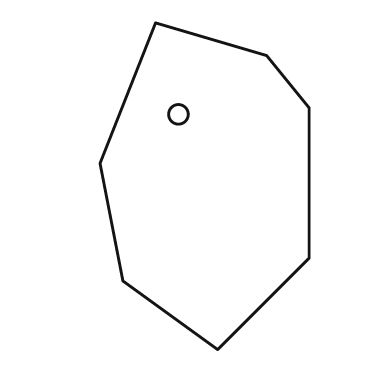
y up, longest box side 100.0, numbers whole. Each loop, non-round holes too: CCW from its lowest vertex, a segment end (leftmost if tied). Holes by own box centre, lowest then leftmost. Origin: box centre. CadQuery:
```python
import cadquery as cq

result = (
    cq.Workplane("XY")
    .moveTo(4.0, -50.0)
    .lineTo(32.0, -22.0)
    .lineTo(32.0, 24.0)
    .lineTo(19.0, 40.0)
    .lineTo(-15.0, 50.0)
    .lineTo(-32.0, 7.0)
    .lineTo(-25.0, -29.0)
    .close()
    .moveTo(-8.0, 22.0)
    .circle(3.0)
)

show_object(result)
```